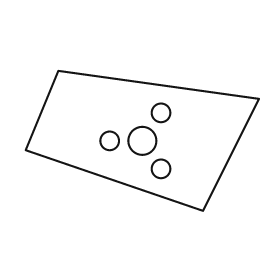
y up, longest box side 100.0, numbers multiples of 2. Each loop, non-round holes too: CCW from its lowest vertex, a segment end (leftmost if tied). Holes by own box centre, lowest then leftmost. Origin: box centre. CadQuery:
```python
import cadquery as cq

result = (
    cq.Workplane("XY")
    .moveTo(26.0, -30.0)
    .lineTo(50.0, 18.0)
    .lineTo(-36.0, 30.0)
    .lineTo(-50.0, -4.0)
    .close()
    .moveTo(8.0, -12.0)
    .circle(4.0)
    .moveTo(-14.0, 0.0)
    .circle(4.0)
    .moveTo(0.0, 0.0)
    .circle(6.0)
    .moveTo(8.0, 12.0)
    .circle(4.0)
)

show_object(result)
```